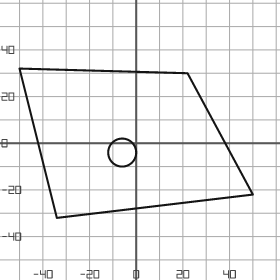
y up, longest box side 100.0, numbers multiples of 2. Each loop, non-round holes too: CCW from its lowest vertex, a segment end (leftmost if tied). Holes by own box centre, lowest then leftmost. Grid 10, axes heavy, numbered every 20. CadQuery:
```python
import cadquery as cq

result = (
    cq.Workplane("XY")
    .moveTo(-34.0, -32.0)
    .lineTo(50.0, -22.0)
    .lineTo(22.0, 30.0)
    .lineTo(-50.0, 32.0)
    .close()
    .moveTo(-6.0, -4.0)
    .circle(6.0)
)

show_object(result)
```